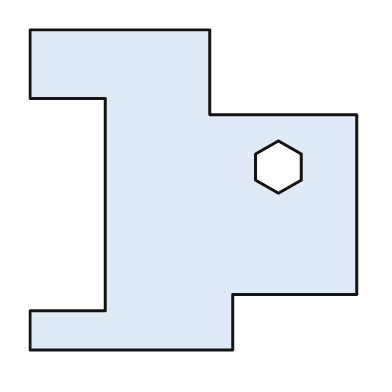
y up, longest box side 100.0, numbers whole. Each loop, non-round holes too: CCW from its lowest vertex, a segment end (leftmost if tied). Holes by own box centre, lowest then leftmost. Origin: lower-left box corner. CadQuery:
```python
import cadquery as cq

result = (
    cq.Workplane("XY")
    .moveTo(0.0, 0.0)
    .lineTo(62.0, 0.0)
    .lineTo(62.0, 17.0)
    .lineTo(100.0, 17.0)
    .lineTo(100.0, 72.0)
    .lineTo(55.0, 72.0)
    .lineTo(55.0, 98.0)
    .lineTo(0.0, 98.0)
    .lineTo(0.0, 77.0)
    .lineTo(23.0, 77.0)
    .lineTo(23.0, 12.0)
    .lineTo(0.0, 12.0)
    .close()
    .moveTo(76.0, 48.0)
    .lineTo(83.0, 52.0)
    .lineTo(83.0, 60.0)
    .lineTo(76.0, 64.0)
    .lineTo(69.0, 60.0)
    .lineTo(69.0, 52.0)
    .close()
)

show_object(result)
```